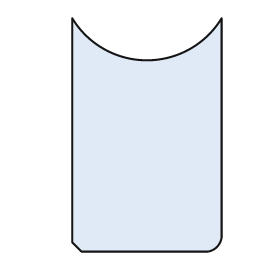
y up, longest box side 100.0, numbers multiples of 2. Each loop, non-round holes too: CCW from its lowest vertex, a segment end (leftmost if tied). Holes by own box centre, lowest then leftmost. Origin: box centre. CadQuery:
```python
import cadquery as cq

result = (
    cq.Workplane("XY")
    .moveTo(-28.0, -50.0)
    .lineTo(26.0, -50.0)
    .threePointArc((30.0, -48.0), (32.0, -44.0))
    .lineTo(32.0, 50.0)
    .threePointArc((0.0, 32.0), (-32.0, 50.0))
    .lineTo(-32.0, -46.0)
    .close()
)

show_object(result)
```